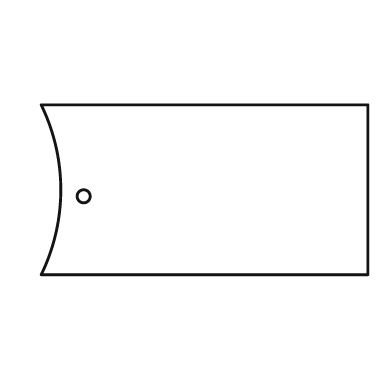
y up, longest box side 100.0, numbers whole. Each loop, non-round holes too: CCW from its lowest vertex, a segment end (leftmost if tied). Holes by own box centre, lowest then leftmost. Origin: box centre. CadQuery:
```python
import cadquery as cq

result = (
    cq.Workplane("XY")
    .moveTo(-50.0, -26.0)
    .lineTo(50.0, -26.0)
    .lineTo(50.0, 26.0)
    .lineTo(-50.0, 26.0)
    .threePointArc((-44.0, 0.0), (-50.0, -26.0))
    .close()
    .moveTo(-37.0, -2.0)
    .circle(2.0)
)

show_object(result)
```